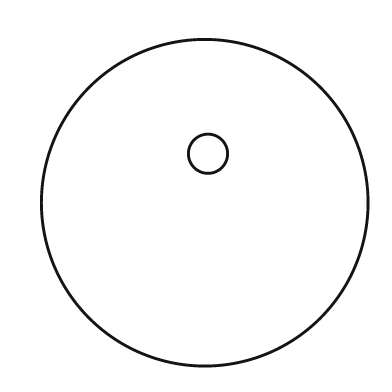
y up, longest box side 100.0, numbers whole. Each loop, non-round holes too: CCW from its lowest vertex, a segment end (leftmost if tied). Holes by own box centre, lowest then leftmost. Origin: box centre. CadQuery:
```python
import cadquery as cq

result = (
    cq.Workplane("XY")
    .moveTo(0.0, 0.0)
    .circle(50.0)
    .moveTo(1.0, 15.0)
    .circle(6.0)
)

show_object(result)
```